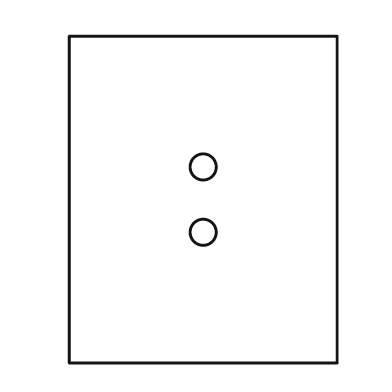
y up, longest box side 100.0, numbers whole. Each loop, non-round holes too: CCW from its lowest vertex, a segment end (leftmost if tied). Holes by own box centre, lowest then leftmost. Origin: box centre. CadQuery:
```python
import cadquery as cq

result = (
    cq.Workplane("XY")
    .moveTo(-41.0, -50.0)
    .lineTo(41.0, -50.0)
    .lineTo(41.0, 50.0)
    .lineTo(-41.0, 50.0)
    .close()
    .moveTo(0.0, -10.0)
    .circle(4.0)
    .moveTo(0.0, 10.0)
    .circle(4.0)
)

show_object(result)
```